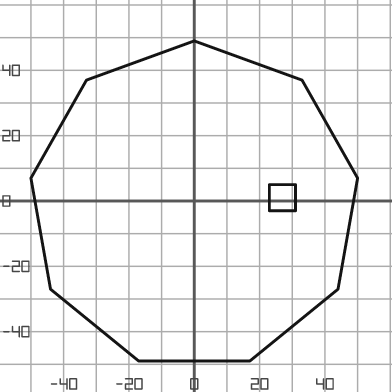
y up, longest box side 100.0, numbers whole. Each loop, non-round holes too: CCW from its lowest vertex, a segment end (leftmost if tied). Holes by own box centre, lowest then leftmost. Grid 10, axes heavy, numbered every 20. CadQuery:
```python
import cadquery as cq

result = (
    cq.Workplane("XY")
    .moveTo(-17.0, -49.0)
    .lineTo(17.0, -49.0)
    .lineTo(44.0, -27.0)
    .lineTo(50.0, 7.0)
    .lineTo(33.0, 37.0)
    .lineTo(0.0, 49.0)
    .lineTo(-33.0, 37.0)
    .lineTo(-50.0, 7.0)
    .lineTo(-44.0, -27.0)
    .close()
    .moveTo(23.0, -3.0)
    .lineTo(31.0, -3.0)
    .lineTo(31.0, 5.0)
    .lineTo(23.0, 5.0)
    .close()
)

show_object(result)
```